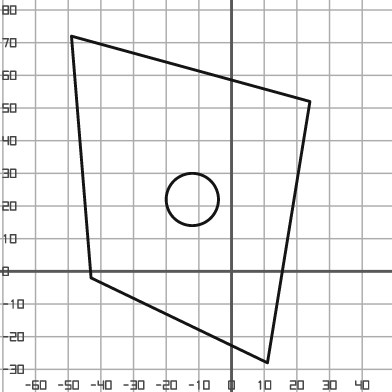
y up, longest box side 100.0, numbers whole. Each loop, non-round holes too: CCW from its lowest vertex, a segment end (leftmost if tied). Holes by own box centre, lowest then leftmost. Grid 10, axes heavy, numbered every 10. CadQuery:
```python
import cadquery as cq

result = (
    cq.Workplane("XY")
    .moveTo(11.0, -28.0)
    .lineTo(24.0, 52.0)
    .lineTo(-49.0, 72.0)
    .lineTo(-43.0, -2.0)
    .close()
    .moveTo(-12.0, 22.0)
    .circle(8.0)
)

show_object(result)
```